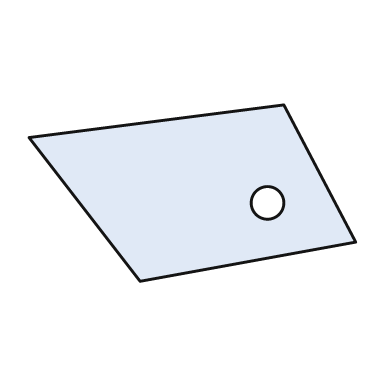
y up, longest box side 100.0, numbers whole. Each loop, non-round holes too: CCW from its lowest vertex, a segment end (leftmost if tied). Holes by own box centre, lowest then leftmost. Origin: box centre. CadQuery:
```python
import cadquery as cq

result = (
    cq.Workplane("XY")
    .moveTo(-16.0, -27.0)
    .lineTo(50.0, -15.0)
    .lineTo(28.0, 27.0)
    .lineTo(-50.0, 17.0)
    .close()
    .moveTo(23.0, -3.0)
    .circle(5.0)
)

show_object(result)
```